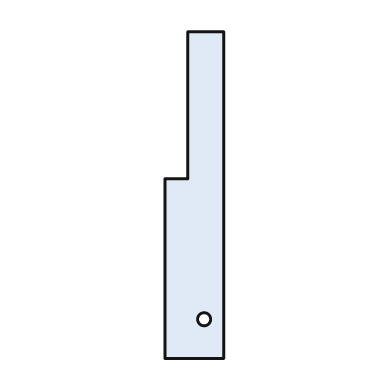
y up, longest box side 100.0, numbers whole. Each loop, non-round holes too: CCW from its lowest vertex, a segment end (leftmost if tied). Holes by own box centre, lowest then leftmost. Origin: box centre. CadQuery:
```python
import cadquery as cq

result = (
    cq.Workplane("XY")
    .moveTo(-9.0, -50.0)
    .lineTo(9.0, -50.0)
    .lineTo(9.0, 50.0)
    .lineTo(-2.0, 50.0)
    .lineTo(-2.0, 5.0)
    .lineTo(-9.0, 5.0)
    .close()
    .moveTo(3.0, -38.0)
    .circle(2.0)
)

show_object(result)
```